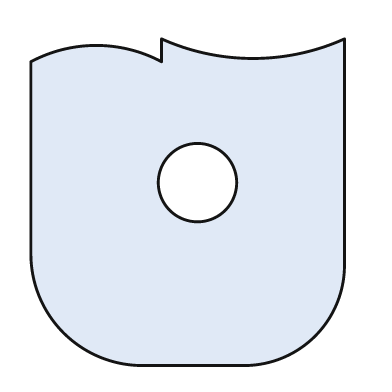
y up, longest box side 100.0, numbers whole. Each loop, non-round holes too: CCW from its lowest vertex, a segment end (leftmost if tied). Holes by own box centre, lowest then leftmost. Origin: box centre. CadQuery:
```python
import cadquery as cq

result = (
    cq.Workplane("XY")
    .moveTo(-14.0, -50.0)
    .lineTo(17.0, -50.0)
    .threePointArc((39.0, -41.0), (48.0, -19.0))
    .lineTo(48.0, 50.0)
    .threePointArc((20.0, 44.0), (-8.0, 50.0))
    .lineTo(-8.0, 43.0)
    .threePointArc((-28.0, 48.0), (-48.0, 43.0))
    .lineTo(-48.0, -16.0)
    .threePointArc((-38.0, -40.0), (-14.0, -50.0))
    .close()
    .moveTo(3.0, 6.0)
    .circle(12.0)
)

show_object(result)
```